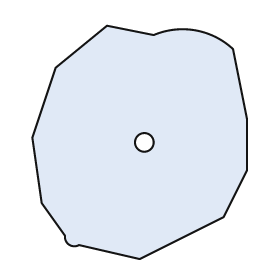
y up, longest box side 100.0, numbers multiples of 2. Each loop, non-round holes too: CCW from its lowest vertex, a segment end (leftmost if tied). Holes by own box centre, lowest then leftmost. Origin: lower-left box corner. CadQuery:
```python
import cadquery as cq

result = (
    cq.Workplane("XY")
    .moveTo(46.0, 0.0)
    .lineTo(82.0, 18.0)
    .lineTo(92.0, 38.0)
    .lineTo(92.0, 60.0)
    .lineTo(86.0, 90.0)
    .threePointArc((70.0, 98.0), (52.0, 96.0))
    .lineTo(32.0, 100.0)
    .lineTo(10.0, 82.0)
    .lineTo(0.0, 52.0)
    .lineTo(4.0, 24.0)
    .lineTo(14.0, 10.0)
    .threePointArc((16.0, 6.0), (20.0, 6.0))
    .close()
    .moveTo(48.0, 50.0)
    .circle(4.0)
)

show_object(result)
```